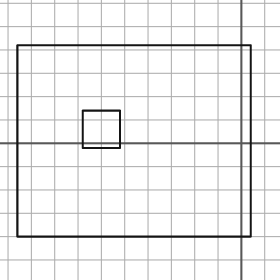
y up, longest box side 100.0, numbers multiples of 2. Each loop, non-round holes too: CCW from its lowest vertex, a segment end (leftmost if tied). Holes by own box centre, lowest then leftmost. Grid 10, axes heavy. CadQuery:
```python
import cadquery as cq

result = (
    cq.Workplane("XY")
    .moveTo(-96.0, -40.0)
    .lineTo(4.0, -40.0)
    .lineTo(4.0, 42.0)
    .lineTo(-96.0, 42.0)
    .close()
    .moveTo(-68.0, -2.0)
    .lineTo(-52.0, -2.0)
    .lineTo(-52.0, 14.0)
    .lineTo(-68.0, 14.0)
    .close()
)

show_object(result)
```